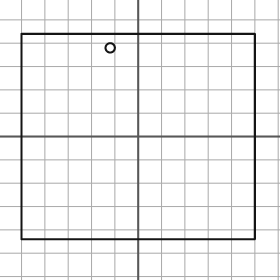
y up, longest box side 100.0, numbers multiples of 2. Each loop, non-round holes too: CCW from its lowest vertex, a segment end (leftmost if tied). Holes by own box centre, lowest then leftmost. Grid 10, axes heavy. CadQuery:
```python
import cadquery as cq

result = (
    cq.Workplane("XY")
    .moveTo(-50.0, -44.0)
    .lineTo(50.0, -44.0)
    .lineTo(50.0, 44.0)
    .lineTo(-50.0, 44.0)
    .close()
    .moveTo(-12.0, 38.0)
    .circle(2.0)
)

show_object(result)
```